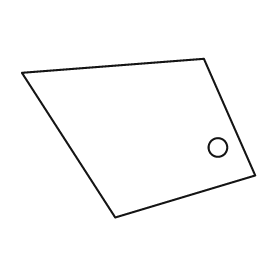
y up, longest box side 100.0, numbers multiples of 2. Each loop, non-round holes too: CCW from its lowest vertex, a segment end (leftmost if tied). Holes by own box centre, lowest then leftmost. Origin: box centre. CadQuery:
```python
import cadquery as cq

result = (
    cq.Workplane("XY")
    .moveTo(-10.0, -34.0)
    .lineTo(50.0, -16.0)
    .lineTo(28.0, 34.0)
    .lineTo(-50.0, 28.0)
    .close()
    .moveTo(34.0, -4.0)
    .circle(4.0)
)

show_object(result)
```